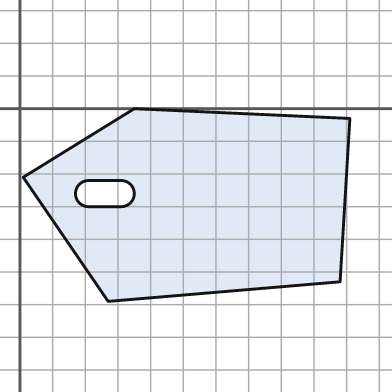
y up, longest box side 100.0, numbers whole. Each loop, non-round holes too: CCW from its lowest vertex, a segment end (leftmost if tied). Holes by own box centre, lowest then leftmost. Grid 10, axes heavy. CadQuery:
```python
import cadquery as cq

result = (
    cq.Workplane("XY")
    .moveTo(27.0, -59.0)
    .lineTo(98.0, -53.0)
    .lineTo(101.0, -3.0)
    .lineTo(35.0, 0.0)
    .lineTo(1.0, -21.0)
    .close()
    .moveTo(21.0, -30.0)
    .lineTo(31.0, -30.0)
    .threePointArc((35.0, -26.0), (31.0, -22.0))
    .lineTo(21.0, -22.0)
    .threePointArc((17.0, -26.0), (21.0, -30.0))
    .close()
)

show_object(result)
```